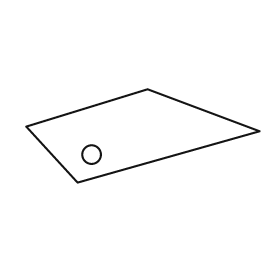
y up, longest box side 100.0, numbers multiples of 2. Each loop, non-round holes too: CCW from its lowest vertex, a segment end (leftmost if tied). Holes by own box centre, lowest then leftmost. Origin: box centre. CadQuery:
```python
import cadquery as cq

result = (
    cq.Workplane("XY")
    .moveTo(-28.0, -20.0)
    .lineTo(50.0, 2.0)
    .lineTo(2.0, 20.0)
    .lineTo(-50.0, 4.0)
    .close()
    .moveTo(-22.0, -8.0)
    .circle(4.0)
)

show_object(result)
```